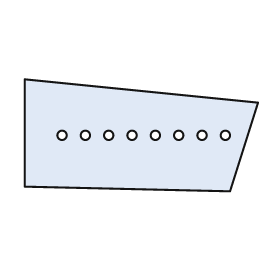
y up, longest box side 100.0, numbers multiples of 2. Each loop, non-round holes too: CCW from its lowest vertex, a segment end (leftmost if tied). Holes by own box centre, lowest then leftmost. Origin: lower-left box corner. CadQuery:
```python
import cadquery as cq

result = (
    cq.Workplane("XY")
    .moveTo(88.0, 0.0)
    .lineTo(100.0, 38.0)
    .lineTo(0.0, 48.0)
    .lineTo(0.0, 2.0)
    .close()
    .moveTo(16.0, 24.0)
    .circle(2.0)
    .moveTo(26.0, 24.0)
    .circle(2.0)
    .moveTo(36.0, 24.0)
    .circle(2.0)
    .moveTo(46.0, 24.0)
    .circle(2.0)
    .moveTo(56.0, 24.0)
    .circle(2.0)
    .moveTo(66.0, 24.0)
    .circle(2.0)
    .moveTo(76.0, 24.0)
    .circle(2.0)
    .moveTo(86.0, 24.0)
    .circle(2.0)
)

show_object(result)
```